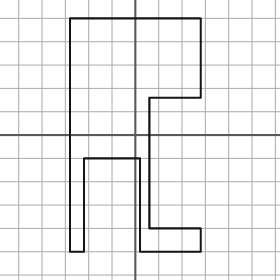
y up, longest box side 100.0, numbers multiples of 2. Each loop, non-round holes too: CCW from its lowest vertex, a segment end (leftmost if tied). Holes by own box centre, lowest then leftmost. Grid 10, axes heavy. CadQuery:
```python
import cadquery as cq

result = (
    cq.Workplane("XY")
    .moveTo(-28.0, -50.0)
    .lineTo(-22.0, -50.0)
    .lineTo(-22.0, -10.0)
    .lineTo(2.0, -10.0)
    .lineTo(2.0, -50.0)
    .lineTo(28.0, -50.0)
    .lineTo(28.0, -40.0)
    .lineTo(6.0, -40.0)
    .lineTo(6.0, 16.0)
    .lineTo(28.0, 16.0)
    .lineTo(28.0, 50.0)
    .lineTo(-28.0, 50.0)
    .close()
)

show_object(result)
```